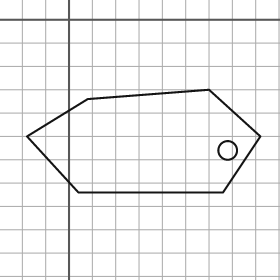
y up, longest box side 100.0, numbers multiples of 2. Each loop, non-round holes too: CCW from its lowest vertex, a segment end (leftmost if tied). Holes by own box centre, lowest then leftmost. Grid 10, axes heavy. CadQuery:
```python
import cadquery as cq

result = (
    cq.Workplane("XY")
    .moveTo(4.0, -74.0)
    .lineTo(66.0, -74.0)
    .lineTo(82.0, -50.0)
    .lineTo(60.0, -30.0)
    .lineTo(8.0, -34.0)
    .lineTo(-18.0, -50.0)
    .close()
    .moveTo(68.0, -56.0)
    .circle(4.0)
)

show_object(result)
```